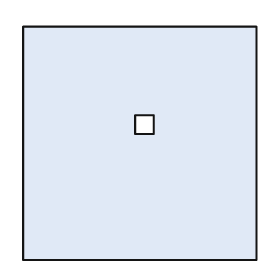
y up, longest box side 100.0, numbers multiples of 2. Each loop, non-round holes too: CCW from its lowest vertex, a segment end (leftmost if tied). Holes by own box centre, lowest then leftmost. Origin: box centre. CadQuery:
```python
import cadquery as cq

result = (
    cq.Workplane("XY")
    .moveTo(-50.0, -50.0)
    .lineTo(50.0, -50.0)
    .lineTo(50.0, 50.0)
    .lineTo(-50.0, 50.0)
    .close()
    .moveTo(-2.0, 4.0)
    .lineTo(6.0, 4.0)
    .lineTo(6.0, 12.0)
    .lineTo(-2.0, 12.0)
    .close()
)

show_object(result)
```